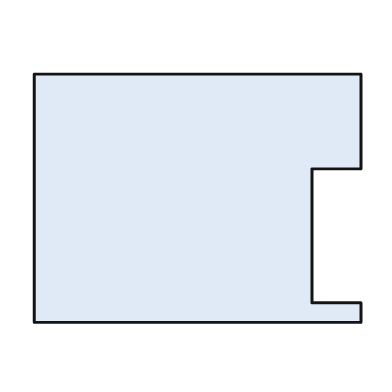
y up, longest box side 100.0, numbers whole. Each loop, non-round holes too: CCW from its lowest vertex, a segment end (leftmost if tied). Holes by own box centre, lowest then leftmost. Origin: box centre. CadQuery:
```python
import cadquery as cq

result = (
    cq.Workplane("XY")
    .moveTo(-50.0, -38.0)
    .lineTo(50.0, -38.0)
    .lineTo(50.0, -32.0)
    .lineTo(35.0, -32.0)
    .lineTo(35.0, 9.0)
    .lineTo(50.0, 9.0)
    .lineTo(50.0, 38.0)
    .lineTo(-50.0, 38.0)
    .close()
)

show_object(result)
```